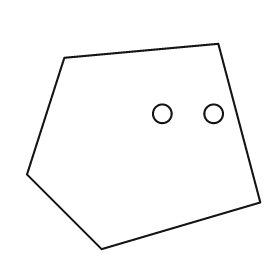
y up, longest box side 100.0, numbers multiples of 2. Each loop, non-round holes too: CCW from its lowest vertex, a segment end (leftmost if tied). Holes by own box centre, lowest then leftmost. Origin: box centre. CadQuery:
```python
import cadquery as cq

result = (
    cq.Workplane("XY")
    .moveTo(-18.0, -44.0)
    .lineTo(50.0, -24.0)
    .lineTo(32.0, 44.0)
    .lineTo(-34.0, 38.0)
    .lineTo(-50.0, -12.0)
    .close()
    .moveTo(8.0, 14.0)
    .circle(4.0)
    .moveTo(30.0, 14.0)
    .circle(4.0)
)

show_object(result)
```